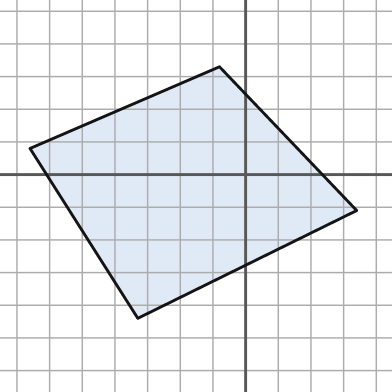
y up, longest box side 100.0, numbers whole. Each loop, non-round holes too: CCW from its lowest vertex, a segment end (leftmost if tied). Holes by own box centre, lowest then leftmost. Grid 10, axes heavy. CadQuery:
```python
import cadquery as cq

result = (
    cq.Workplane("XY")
    .moveTo(-33.0, -44.0)
    .lineTo(34.0, -11.0)
    .lineTo(-8.0, 33.0)
    .lineTo(-66.0, 8.0)
    .close()
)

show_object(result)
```